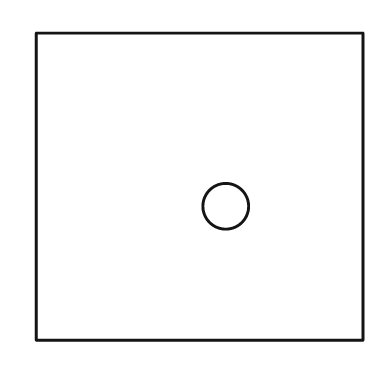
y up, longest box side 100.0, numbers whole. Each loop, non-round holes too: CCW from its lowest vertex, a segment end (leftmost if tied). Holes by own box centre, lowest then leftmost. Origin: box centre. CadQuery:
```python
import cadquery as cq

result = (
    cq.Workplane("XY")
    .moveTo(-50.0, -47.0)
    .lineTo(50.0, -47.0)
    .lineTo(50.0, 47.0)
    .lineTo(-50.0, 47.0)
    .close()
    .moveTo(8.0, -6.0)
    .circle(7.0)
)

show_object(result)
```